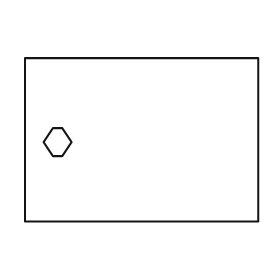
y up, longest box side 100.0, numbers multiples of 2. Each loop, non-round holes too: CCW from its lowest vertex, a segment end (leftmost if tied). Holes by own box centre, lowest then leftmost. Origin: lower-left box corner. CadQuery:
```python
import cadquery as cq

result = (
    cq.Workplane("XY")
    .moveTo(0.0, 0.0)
    .lineTo(100.0, 0.0)
    .lineTo(100.0, 70.0)
    .lineTo(0.0, 70.0)
    .close()
    .moveTo(12.0, 28.0)
    .lineTo(16.0, 28.0)
    .lineTo(20.0, 34.0)
    .lineTo(16.0, 40.0)
    .lineTo(12.0, 40.0)
    .lineTo(8.0, 34.0)
    .close()
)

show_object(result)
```